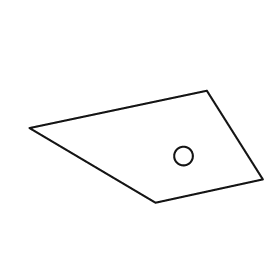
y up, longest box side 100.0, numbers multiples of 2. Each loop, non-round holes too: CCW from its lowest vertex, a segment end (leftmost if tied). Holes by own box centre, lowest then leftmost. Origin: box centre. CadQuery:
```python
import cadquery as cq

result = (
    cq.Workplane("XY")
    .moveTo(4.0, -24.0)
    .lineTo(50.0, -14.0)
    .lineTo(26.0, 24.0)
    .lineTo(-50.0, 8.0)
    .close()
    .moveTo(16.0, -4.0)
    .circle(4.0)
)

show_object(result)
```